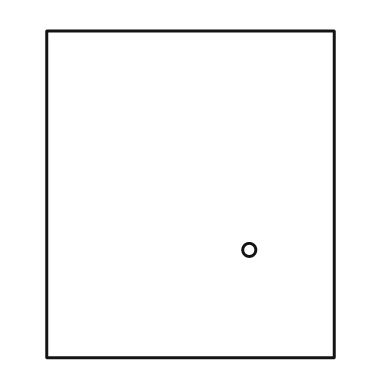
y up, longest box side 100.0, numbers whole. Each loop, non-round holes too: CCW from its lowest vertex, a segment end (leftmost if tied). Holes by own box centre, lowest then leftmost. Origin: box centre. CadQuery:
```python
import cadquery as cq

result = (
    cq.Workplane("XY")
    .moveTo(-44.0, -50.0)
    .lineTo(44.0, -50.0)
    .lineTo(44.0, 50.0)
    .lineTo(-44.0, 50.0)
    .close()
    .moveTo(18.0, -17.0)
    .circle(2.0)
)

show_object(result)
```